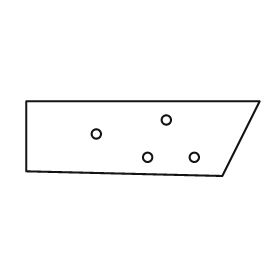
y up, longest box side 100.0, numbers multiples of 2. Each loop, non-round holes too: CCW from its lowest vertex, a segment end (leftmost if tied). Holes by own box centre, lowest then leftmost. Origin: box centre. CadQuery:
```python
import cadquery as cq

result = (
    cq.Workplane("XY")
    .moveTo(34.0, -16.0)
    .lineTo(50.0, 16.0)
    .lineTo(-50.0, 16.0)
    .lineTo(-50.0, -14.0)
    .close()
    .moveTo(2.0, -8.0)
    .circle(2.0)
    .moveTo(22.0, -8.0)
    .circle(2.0)
    .moveTo(-20.0, 2.0)
    .circle(2.0)
    .moveTo(10.0, 8.0)
    .circle(2.0)
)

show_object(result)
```